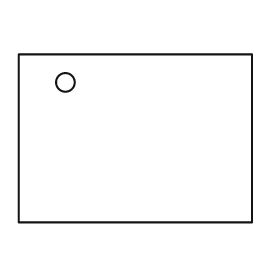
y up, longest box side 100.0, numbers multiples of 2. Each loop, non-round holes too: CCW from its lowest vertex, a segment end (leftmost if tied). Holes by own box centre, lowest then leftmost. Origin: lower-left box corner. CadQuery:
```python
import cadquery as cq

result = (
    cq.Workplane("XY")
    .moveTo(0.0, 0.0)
    .lineTo(100.0, 0.0)
    .lineTo(100.0, 72.0)
    .lineTo(0.0, 72.0)
    .close()
    .moveTo(20.0, 60.0)
    .circle(4.0)
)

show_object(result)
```